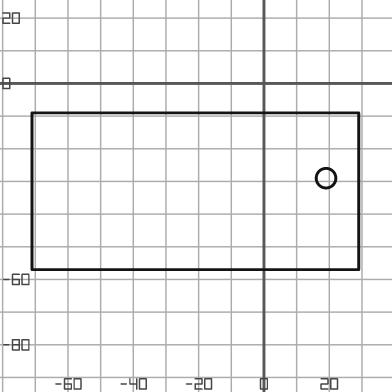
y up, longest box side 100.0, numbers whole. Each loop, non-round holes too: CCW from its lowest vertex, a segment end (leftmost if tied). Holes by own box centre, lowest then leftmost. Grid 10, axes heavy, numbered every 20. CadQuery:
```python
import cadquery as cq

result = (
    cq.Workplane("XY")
    .moveTo(-71.0, -57.0)
    .lineTo(29.0, -57.0)
    .lineTo(29.0, -9.0)
    .lineTo(-71.0, -9.0)
    .close()
    .moveTo(19.0, -29.0)
    .circle(3.0)
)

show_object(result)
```